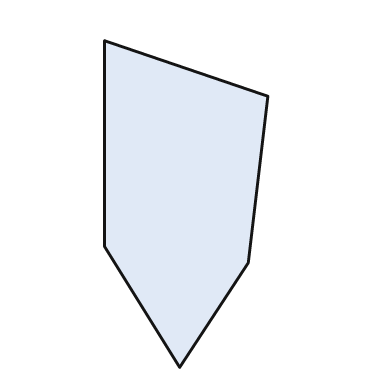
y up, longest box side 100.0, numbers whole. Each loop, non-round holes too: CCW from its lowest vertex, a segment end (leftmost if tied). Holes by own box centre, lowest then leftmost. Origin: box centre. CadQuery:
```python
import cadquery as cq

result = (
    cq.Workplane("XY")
    .moveTo(-2.0, -50.0)
    .lineTo(19.0, -18.0)
    .lineTo(25.0, 33.0)
    .lineTo(-25.0, 50.0)
    .lineTo(-25.0, -13.0)
    .close()
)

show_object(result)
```